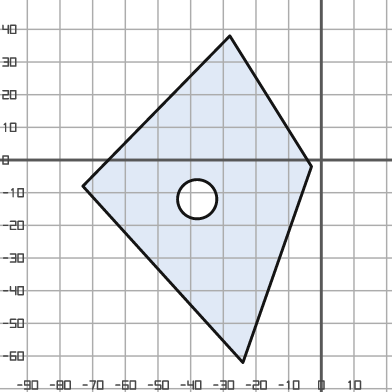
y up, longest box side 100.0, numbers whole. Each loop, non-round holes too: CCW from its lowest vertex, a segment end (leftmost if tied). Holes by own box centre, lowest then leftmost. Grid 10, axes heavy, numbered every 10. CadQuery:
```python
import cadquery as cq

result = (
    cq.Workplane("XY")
    .moveTo(-24.0, -62.0)
    .lineTo(-3.0, -2.0)
    .lineTo(-28.0, 38.0)
    .lineTo(-73.0, -8.0)
    .close()
    .moveTo(-38.0, -12.0)
    .circle(6.0)
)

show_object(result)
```